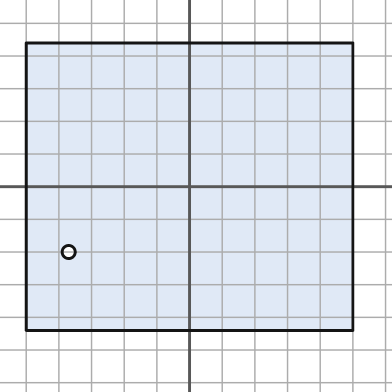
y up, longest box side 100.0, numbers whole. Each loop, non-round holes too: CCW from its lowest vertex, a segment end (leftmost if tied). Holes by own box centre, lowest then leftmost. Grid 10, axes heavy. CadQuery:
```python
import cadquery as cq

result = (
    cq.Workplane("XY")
    .moveTo(-50.0, -44.0)
    .lineTo(50.0, -44.0)
    .lineTo(50.0, 44.0)
    .lineTo(-50.0, 44.0)
    .close()
    .moveTo(-37.0, -20.0)
    .circle(2.0)
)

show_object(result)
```